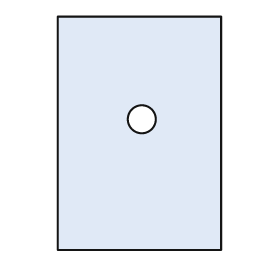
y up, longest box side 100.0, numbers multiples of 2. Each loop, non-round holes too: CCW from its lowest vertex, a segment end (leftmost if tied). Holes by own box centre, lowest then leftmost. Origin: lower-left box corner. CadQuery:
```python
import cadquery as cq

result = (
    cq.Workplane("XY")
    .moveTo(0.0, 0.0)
    .lineTo(70.0, 0.0)
    .lineTo(70.0, 100.0)
    .lineTo(0.0, 100.0)
    .close()
    .moveTo(36.0, 56.0)
    .circle(6.0)
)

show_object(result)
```